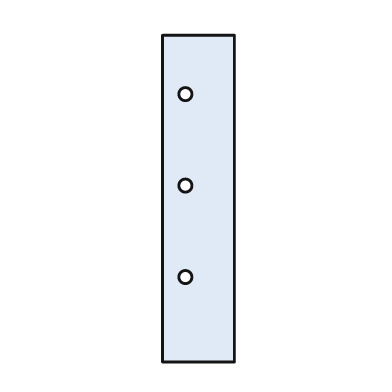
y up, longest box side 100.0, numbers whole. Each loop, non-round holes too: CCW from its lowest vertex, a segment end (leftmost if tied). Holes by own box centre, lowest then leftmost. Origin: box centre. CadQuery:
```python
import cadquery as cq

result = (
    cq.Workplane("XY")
    .moveTo(-11.0, -50.0)
    .lineTo(11.0, -50.0)
    .lineTo(11.0, 50.0)
    .lineTo(-11.0, 50.0)
    .close()
    .moveTo(-4.0, -24.0)
    .circle(2.0)
    .moveTo(-4.0, 4.0)
    .circle(2.0)
    .moveTo(-4.0, 32.0)
    .circle(2.0)
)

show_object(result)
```